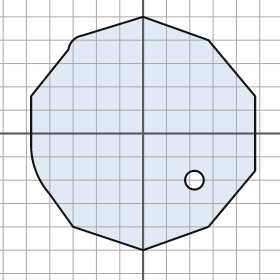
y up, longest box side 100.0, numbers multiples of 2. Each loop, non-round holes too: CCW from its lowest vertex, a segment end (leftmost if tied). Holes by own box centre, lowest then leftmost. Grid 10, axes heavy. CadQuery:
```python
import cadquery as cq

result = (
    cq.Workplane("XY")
    .moveTo(0.0, -50.0)
    .lineTo(28.0, -40.0)
    .lineTo(48.0, -16.0)
    .lineTo(48.0, 16.0)
    .lineTo(28.0, 40.0)
    .lineTo(0.0, 50.0)
    .lineTo(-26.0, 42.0)
    .threePointArc((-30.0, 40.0), (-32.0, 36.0))
    .lineTo(-48.0, 16.0)
    .lineTo(-48.0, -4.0)
    .threePointArc((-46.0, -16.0), (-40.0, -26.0))
    .lineTo(-30.0, -40.0)
    .close()
    .moveTo(22.0, -20.0)
    .circle(4.0)
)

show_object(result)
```